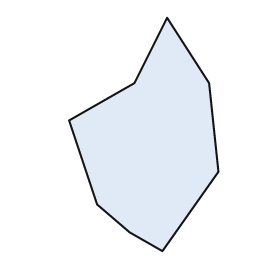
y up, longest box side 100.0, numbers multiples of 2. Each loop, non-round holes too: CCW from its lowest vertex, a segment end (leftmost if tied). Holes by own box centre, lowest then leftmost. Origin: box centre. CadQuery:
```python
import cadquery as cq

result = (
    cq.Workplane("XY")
    .moveTo(8.0, -50.0)
    .lineTo(32.0, -16.0)
    .lineTo(28.0, 22.0)
    .lineTo(10.0, 50.0)
    .lineTo(-4.0, 22.0)
    .lineTo(-32.0, 6.0)
    .lineTo(-20.0, -30.0)
    .lineTo(-6.0, -42.0)
    .close()
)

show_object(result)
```